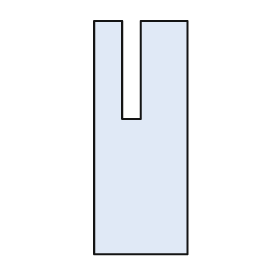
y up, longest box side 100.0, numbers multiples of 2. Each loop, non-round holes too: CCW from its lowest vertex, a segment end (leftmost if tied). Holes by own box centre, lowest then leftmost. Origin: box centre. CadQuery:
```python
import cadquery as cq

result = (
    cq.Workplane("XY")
    .moveTo(-20.0, -50.0)
    .lineTo(20.0, -50.0)
    .lineTo(20.0, 50.0)
    .lineTo(0.0, 50.0)
    .lineTo(0.0, 8.0)
    .lineTo(-8.0, 8.0)
    .lineTo(-8.0, 50.0)
    .lineTo(-20.0, 50.0)
    .close()
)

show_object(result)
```